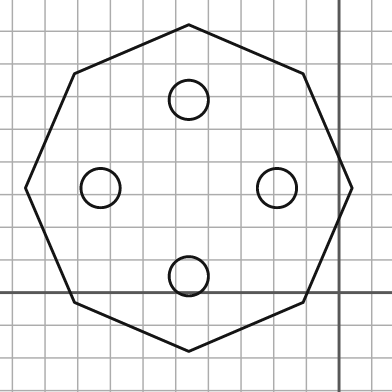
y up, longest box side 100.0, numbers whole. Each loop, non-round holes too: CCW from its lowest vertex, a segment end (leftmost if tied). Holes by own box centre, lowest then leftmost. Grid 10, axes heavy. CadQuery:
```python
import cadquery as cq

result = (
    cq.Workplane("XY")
    .moveTo(-46.0, -18.0)
    .lineTo(-11.0, -3.0)
    .lineTo(4.0, 32.0)
    .lineTo(-11.0, 67.0)
    .lineTo(-46.0, 82.0)
    .lineTo(-81.0, 67.0)
    .lineTo(-96.0, 32.0)
    .lineTo(-81.0, -3.0)
    .close()
    .moveTo(-46.0, 5.0)
    .circle(6.0)
    .moveTo(-73.0, 32.0)
    .circle(6.0)
    .moveTo(-19.0, 32.0)
    .circle(6.0)
    .moveTo(-46.0, 59.0)
    .circle(6.0)
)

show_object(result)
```